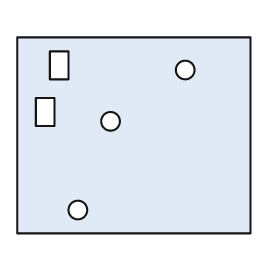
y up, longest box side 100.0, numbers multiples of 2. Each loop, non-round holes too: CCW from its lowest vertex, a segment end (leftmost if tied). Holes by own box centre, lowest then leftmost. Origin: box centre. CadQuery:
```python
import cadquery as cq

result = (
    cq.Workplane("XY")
    .moveTo(-50.0, -42.0)
    .lineTo(50.0, -42.0)
    .lineTo(50.0, 42.0)
    .lineTo(-50.0, 42.0)
    .close()
    .moveTo(-24.0, -32.0)
    .circle(4.0)
    .moveTo(-10.0, 6.0)
    .circle(4.0)
    .moveTo(-42.0, 4.0)
    .lineTo(-34.0, 4.0)
    .lineTo(-34.0, 16.0)
    .lineTo(-42.0, 16.0)
    .close()
    .moveTo(22.0, 28.0)
    .circle(4.0)
    .moveTo(-36.0, 24.0)
    .lineTo(-28.0, 24.0)
    .lineTo(-28.0, 36.0)
    .lineTo(-36.0, 36.0)
    .close()
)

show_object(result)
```